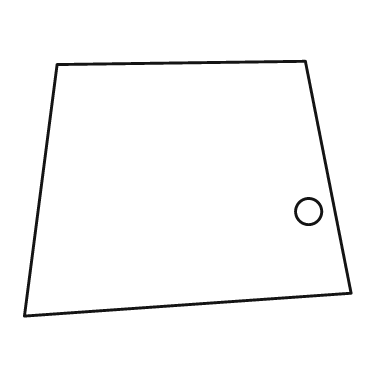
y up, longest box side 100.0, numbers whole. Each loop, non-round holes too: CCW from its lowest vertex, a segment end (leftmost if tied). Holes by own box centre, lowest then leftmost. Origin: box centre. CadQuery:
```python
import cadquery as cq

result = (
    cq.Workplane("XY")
    .moveTo(-50.0, -39.0)
    .lineTo(50.0, -32.0)
    .lineTo(36.0, 39.0)
    .lineTo(-40.0, 38.0)
    .close()
    .moveTo(37.0, -7.0)
    .circle(4.0)
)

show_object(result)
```